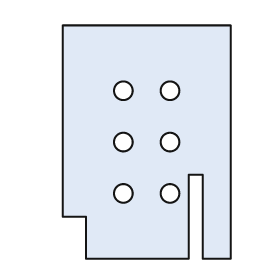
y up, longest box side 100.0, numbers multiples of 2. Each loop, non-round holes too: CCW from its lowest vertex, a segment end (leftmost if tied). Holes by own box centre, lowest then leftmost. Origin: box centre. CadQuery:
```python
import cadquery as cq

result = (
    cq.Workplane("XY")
    .moveTo(-26.0, -50.0)
    .lineTo(18.0, -50.0)
    .lineTo(18.0, -14.0)
    .lineTo(24.0, -14.0)
    .lineTo(24.0, -50.0)
    .lineTo(36.0, -50.0)
    .lineTo(36.0, 50.0)
    .lineTo(-36.0, 50.0)
    .lineTo(-36.0, -32.0)
    .lineTo(-26.0, -32.0)
    .close()
    .moveTo(-10.0, -22.0)
    .circle(4.0)
    .moveTo(10.0, -22.0)
    .circle(4.0)
    .moveTo(-10.0, 0.0)
    .circle(4.0)
    .moveTo(10.0, 0.0)
    .circle(4.0)
    .moveTo(-10.0, 22.0)
    .circle(4.0)
    .moveTo(10.0, 22.0)
    .circle(4.0)
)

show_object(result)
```